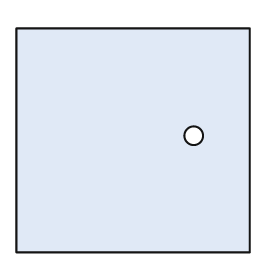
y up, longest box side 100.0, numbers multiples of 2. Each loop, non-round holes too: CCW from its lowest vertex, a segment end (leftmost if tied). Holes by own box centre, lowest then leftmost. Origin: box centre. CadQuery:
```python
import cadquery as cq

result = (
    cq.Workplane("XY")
    .moveTo(-50.0, -48.0)
    .lineTo(50.0, -48.0)
    .lineTo(50.0, 48.0)
    .lineTo(-50.0, 48.0)
    .close()
    .moveTo(26.0, 2.0)
    .circle(4.0)
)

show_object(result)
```